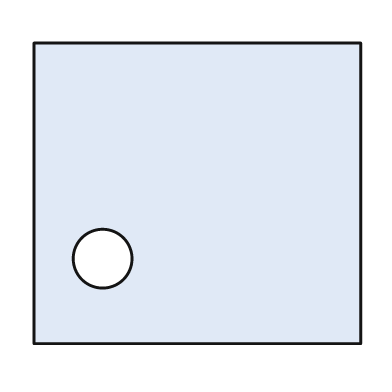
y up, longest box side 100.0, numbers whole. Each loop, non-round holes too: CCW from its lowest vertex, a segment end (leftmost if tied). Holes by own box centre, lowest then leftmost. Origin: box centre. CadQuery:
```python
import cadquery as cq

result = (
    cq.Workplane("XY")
    .moveTo(-50.0, -46.0)
    .lineTo(50.0, -46.0)
    .lineTo(50.0, 46.0)
    .lineTo(-50.0, 46.0)
    .close()
    .moveTo(-29.0, -20.0)
    .circle(9.0)
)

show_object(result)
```